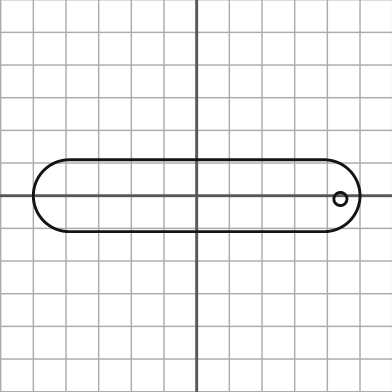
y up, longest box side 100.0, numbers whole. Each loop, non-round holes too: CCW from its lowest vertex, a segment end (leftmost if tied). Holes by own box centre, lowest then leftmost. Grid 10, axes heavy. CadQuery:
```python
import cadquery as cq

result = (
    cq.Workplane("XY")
    .moveTo(-39.0, -11.0)
    .lineTo(39.0, -11.0)
    .threePointArc((50.0, 0.0), (39.0, 11.0))
    .lineTo(-39.0, 11.0)
    .threePointArc((-50.0, 0.0), (-39.0, -11.0))
    .close()
    .moveTo(44.0, -1.0)
    .circle(2.0)
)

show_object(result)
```